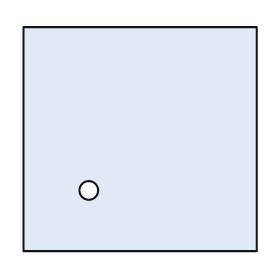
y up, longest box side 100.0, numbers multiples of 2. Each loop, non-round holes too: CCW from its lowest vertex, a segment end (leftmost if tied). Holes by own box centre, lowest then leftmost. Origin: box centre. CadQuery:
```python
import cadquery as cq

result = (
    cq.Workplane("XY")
    .moveTo(-50.0, -48.0)
    .lineTo(50.0, -48.0)
    .lineTo(50.0, 48.0)
    .lineTo(-50.0, 48.0)
    .close()
    .moveTo(-22.0, -22.0)
    .circle(4.0)
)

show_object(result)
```